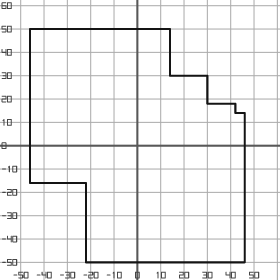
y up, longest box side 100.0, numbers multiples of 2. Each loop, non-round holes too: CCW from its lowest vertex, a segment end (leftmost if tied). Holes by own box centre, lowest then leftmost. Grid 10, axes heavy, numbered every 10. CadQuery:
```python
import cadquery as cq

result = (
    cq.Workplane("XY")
    .moveTo(-22.0, -50.0)
    .lineTo(46.0, -50.0)
    .lineTo(46.0, 14.0)
    .lineTo(42.0, 14.0)
    .lineTo(42.0, 18.0)
    .lineTo(30.0, 18.0)
    .lineTo(30.0, 30.0)
    .lineTo(14.0, 30.0)
    .lineTo(14.0, 50.0)
    .lineTo(-46.0, 50.0)
    .lineTo(-46.0, -16.0)
    .lineTo(-22.0, -16.0)
    .close()
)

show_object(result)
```